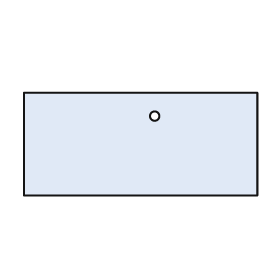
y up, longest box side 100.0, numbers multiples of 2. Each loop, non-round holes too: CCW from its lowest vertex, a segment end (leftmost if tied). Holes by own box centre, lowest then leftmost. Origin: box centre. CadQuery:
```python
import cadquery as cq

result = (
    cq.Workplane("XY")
    .moveTo(-50.0, -22.0)
    .lineTo(50.0, -22.0)
    .lineTo(50.0, 22.0)
    .lineTo(-50.0, 22.0)
    .close()
    .moveTo(6.0, 12.0)
    .circle(2.0)
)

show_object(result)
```